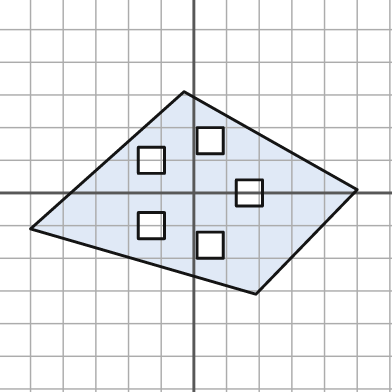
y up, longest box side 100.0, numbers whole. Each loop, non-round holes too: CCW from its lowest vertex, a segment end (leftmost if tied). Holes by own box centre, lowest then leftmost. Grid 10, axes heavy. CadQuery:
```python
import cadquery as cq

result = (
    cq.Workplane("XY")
    .moveTo(19.0, -31.0)
    .lineTo(50.0, 1.0)
    .lineTo(-3.0, 31.0)
    .lineTo(-50.0, -11.0)
    .close()
    .moveTo(1.0, -20.0)
    .lineTo(9.0, -20.0)
    .lineTo(9.0, -12.0)
    .lineTo(1.0, -12.0)
    .close()
    .moveTo(-17.0, -14.0)
    .lineTo(-9.0, -14.0)
    .lineTo(-9.0, -6.0)
    .lineTo(-17.0, -6.0)
    .close()
    .moveTo(13.0, -4.0)
    .lineTo(21.0, -4.0)
    .lineTo(21.0, 4.0)
    .lineTo(13.0, 4.0)
    .close()
    .moveTo(-17.0, 6.0)
    .lineTo(-9.0, 6.0)
    .lineTo(-9.0, 14.0)
    .lineTo(-17.0, 14.0)
    .close()
    .moveTo(1.0, 12.0)
    .lineTo(9.0, 12.0)
    .lineTo(9.0, 20.0)
    .lineTo(1.0, 20.0)
    .close()
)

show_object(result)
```